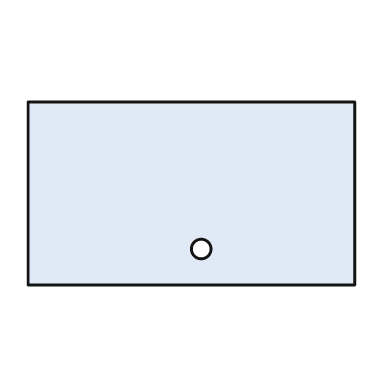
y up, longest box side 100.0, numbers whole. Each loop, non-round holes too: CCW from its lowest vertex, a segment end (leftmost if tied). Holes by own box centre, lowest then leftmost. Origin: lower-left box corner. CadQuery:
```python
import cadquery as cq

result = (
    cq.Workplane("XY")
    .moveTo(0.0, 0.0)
    .lineTo(100.0, 0.0)
    .lineTo(100.0, 56.0)
    .lineTo(0.0, 56.0)
    .close()
    .moveTo(53.0, 11.0)
    .circle(3.0)
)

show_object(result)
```